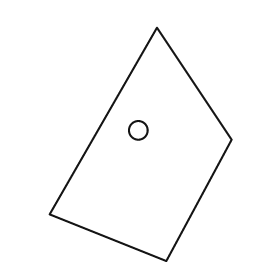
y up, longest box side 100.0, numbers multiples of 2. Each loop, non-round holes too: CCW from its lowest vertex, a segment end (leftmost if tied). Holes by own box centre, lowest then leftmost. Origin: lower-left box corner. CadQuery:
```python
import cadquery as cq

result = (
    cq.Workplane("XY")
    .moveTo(50.0, 0.0)
    .lineTo(78.0, 52.0)
    .lineTo(46.0, 100.0)
    .lineTo(0.0, 20.0)
    .close()
    .moveTo(38.0, 56.0)
    .circle(4.0)
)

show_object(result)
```